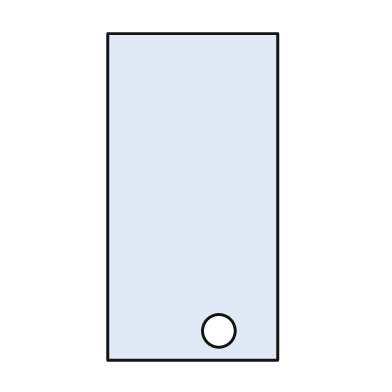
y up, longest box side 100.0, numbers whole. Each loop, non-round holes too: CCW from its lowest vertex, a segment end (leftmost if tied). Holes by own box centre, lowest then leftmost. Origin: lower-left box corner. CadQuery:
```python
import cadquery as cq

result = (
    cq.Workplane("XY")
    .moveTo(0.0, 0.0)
    .lineTo(52.0, 0.0)
    .lineTo(52.0, 100.0)
    .lineTo(0.0, 100.0)
    .close()
    .moveTo(34.0, 9.0)
    .circle(5.0)
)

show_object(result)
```